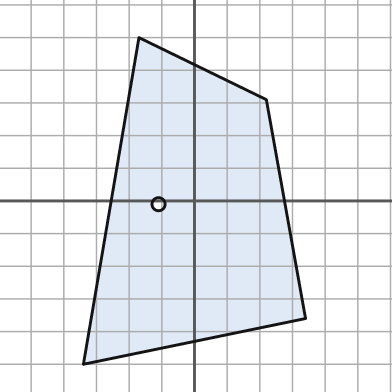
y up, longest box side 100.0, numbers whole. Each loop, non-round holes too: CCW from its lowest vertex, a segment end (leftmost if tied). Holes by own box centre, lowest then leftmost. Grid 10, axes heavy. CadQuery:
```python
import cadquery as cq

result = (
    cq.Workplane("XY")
    .moveTo(-34.0, -50.0)
    .lineTo(34.0, -36.0)
    .lineTo(22.0, 31.0)
    .lineTo(-17.0, 50.0)
    .close()
    .moveTo(-11.0, -1.0)
    .circle(2.0)
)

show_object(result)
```